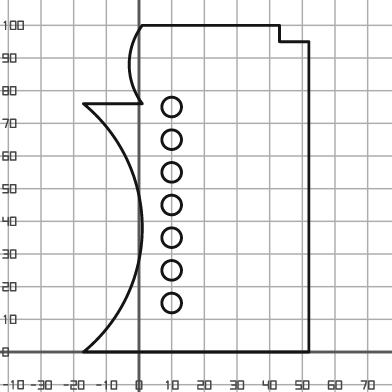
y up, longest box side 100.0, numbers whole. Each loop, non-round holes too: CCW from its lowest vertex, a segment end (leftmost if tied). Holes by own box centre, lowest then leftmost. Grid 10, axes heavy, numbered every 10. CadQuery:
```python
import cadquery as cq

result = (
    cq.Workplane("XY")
    .moveTo(-17.0, 0.0)
    .lineTo(52.0, 0.0)
    .lineTo(52.0, 95.0)
    .lineTo(43.0, 95.0)
    .lineTo(43.0, 100.0)
    .lineTo(1.0, 100.0)
    .threePointArc((-3.0, 88.0), (1.0, 76.0))
    .lineTo(-17.0, 76.0)
    .threePointArc((1.0, 38.0), (-17.0, 0.0))
    .close()
    .moveTo(10.0, 15.0)
    .circle(3.0)
    .moveTo(10.0, 25.0)
    .circle(3.0)
    .moveTo(10.0, 35.0)
    .circle(3.0)
    .moveTo(10.0, 45.0)
    .circle(3.0)
    .moveTo(10.0, 55.0)
    .circle(3.0)
    .moveTo(10.0, 65.0)
    .circle(3.0)
    .moveTo(10.0, 75.0)
    .circle(3.0)
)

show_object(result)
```